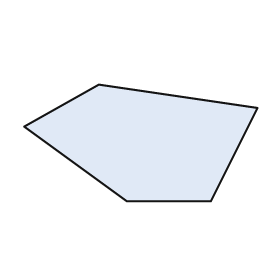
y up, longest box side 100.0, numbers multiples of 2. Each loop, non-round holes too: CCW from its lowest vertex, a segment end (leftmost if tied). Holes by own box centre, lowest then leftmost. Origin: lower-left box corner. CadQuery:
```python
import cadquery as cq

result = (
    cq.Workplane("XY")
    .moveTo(44.0, 0.0)
    .lineTo(80.0, 0.0)
    .lineTo(100.0, 40.0)
    .lineTo(32.0, 50.0)
    .lineTo(0.0, 32.0)
    .close()
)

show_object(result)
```